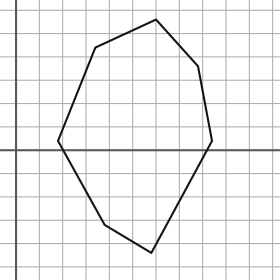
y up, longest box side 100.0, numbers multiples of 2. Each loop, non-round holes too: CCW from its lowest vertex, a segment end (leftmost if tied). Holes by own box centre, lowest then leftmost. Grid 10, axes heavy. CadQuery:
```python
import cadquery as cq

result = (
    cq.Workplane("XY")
    .moveTo(58.0, -44.0)
    .lineTo(84.0, 4.0)
    .lineTo(78.0, 36.0)
    .lineTo(60.0, 56.0)
    .lineTo(34.0, 44.0)
    .lineTo(18.0, 4.0)
    .lineTo(38.0, -32.0)
    .close()
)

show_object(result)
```